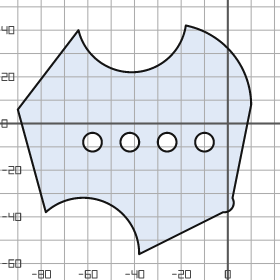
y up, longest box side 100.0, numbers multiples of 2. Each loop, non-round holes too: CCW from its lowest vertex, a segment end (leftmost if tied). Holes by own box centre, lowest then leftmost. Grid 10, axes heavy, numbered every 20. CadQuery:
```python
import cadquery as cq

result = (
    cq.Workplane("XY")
    .moveTo(-38.0, -56.0)
    .lineTo(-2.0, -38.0)
    .threePointArc((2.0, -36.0), (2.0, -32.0))
    .lineTo(10.0, 8.0)
    .threePointArc((2.0, 30.0), (-18.0, 42.0))
    .threePointArc((-40.0, 22.0), (-64.0, 40.0))
    .lineTo(-90.0, 6.0)
    .lineTo(-78.0, -38.0)
    .threePointArc((-52.0, -34.0), (-38.0, -56.0))
    .close()
    .moveTo(-58.0, -8.0)
    .circle(4.0)
    .moveTo(-42.0, -8.0)
    .circle(4.0)
    .moveTo(-26.0, -8.0)
    .circle(4.0)
    .moveTo(-10.0, -8.0)
    .circle(4.0)
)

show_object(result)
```